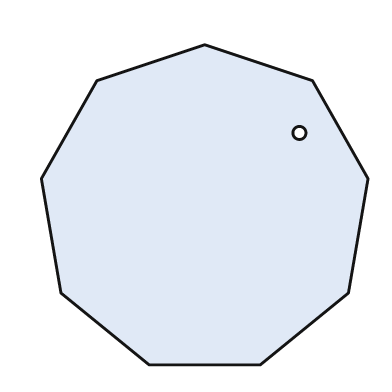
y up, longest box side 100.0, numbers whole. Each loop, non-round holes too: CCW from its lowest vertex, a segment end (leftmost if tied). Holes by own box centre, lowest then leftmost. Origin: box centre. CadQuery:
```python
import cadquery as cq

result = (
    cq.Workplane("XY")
    .moveTo(-17.0, -49.0)
    .lineTo(17.0, -49.0)
    .lineTo(44.0, -27.0)
    .lineTo(50.0, 8.0)
    .lineTo(33.0, 38.0)
    .lineTo(0.0, 49.0)
    .lineTo(-33.0, 38.0)
    .lineTo(-50.0, 8.0)
    .lineTo(-44.0, -27.0)
    .close()
    .moveTo(29.0, 22.0)
    .circle(2.0)
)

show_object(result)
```